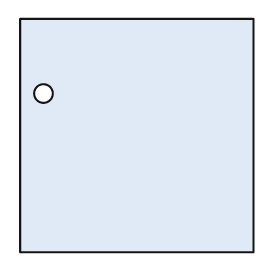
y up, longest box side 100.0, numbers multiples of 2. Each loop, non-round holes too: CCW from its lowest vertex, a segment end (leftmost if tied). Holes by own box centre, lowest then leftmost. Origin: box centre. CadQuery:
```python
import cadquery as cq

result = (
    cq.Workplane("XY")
    .moveTo(-50.0, -50.0)
    .lineTo(50.0, -50.0)
    .lineTo(50.0, 50.0)
    .lineTo(-50.0, 50.0)
    .close()
    .moveTo(-40.0, 18.0)
    .circle(4.0)
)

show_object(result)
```